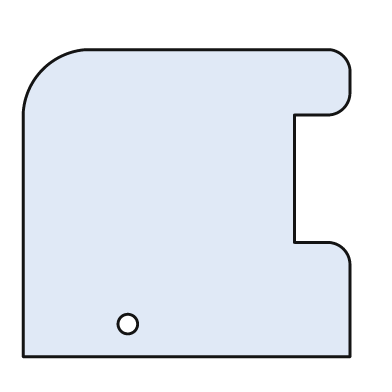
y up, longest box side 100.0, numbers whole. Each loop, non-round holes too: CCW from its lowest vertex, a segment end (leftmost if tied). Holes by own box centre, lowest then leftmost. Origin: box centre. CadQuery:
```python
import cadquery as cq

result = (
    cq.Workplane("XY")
    .moveTo(-50.0, -47.0)
    .lineTo(50.0, -47.0)
    .lineTo(50.0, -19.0)
    .threePointArc((48.0, -14.0), (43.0, -12.0))
    .lineTo(33.0, -12.0)
    .lineTo(33.0, 27.0)
    .lineTo(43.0, 27.0)
    .threePointArc((48.0, 29.0), (50.0, 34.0))
    .lineTo(50.0, 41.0)
    .threePointArc((48.0, 45.0), (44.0, 47.0))
    .lineTo(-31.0, 47.0)
    .threePointArc((-44.0, 41.0), (-50.0, 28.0))
    .close()
    .moveTo(-18.0, -37.0)
    .circle(3.0)
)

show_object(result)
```